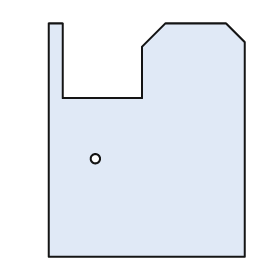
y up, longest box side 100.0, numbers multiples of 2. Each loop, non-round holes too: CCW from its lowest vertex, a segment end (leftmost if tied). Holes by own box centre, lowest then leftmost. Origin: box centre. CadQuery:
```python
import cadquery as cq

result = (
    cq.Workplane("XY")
    .moveTo(-42.0, -50.0)
    .lineTo(42.0, -50.0)
    .lineTo(42.0, 42.0)
    .lineTo(34.0, 50.0)
    .lineTo(8.0, 50.0)
    .lineTo(-2.0, 40.0)
    .lineTo(-2.0, 18.0)
    .lineTo(-36.0, 18.0)
    .lineTo(-36.0, 50.0)
    .lineTo(-42.0, 50.0)
    .close()
    .moveTo(-22.0, -8.0)
    .circle(2.0)
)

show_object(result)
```